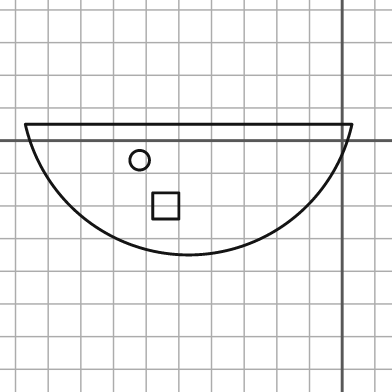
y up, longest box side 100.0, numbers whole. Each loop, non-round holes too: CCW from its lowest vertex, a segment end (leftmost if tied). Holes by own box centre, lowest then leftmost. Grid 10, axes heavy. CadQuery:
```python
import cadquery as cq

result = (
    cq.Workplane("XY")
    .moveTo(-97.0, 5.0)
    .threePointArc((-47.0, -35.0), (3.0, 5.0))
    .close()
    .moveTo(-58.0, -24.0)
    .lineTo(-50.0, -24.0)
    .lineTo(-50.0, -16.0)
    .lineTo(-58.0, -16.0)
    .close()
    .moveTo(-62.0, -6.0)
    .circle(3.0)
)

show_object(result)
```